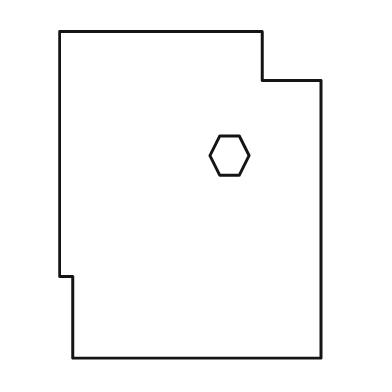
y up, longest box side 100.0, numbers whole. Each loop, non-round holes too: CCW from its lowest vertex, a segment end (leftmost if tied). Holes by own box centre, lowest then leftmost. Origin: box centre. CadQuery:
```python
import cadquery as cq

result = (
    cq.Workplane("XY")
    .moveTo(-36.0, -50.0)
    .lineTo(40.0, -50.0)
    .lineTo(40.0, 35.0)
    .lineTo(22.0, 35.0)
    .lineTo(22.0, 50.0)
    .lineTo(-40.0, 50.0)
    .lineTo(-40.0, -25.0)
    .lineTo(-36.0, -25.0)
    .close()
    .moveTo(9.0, 6.0)
    .lineTo(15.0, 6.0)
    .lineTo(18.0, 12.0)
    .lineTo(15.0, 18.0)
    .lineTo(9.0, 18.0)
    .lineTo(6.0, 12.0)
    .close()
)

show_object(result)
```